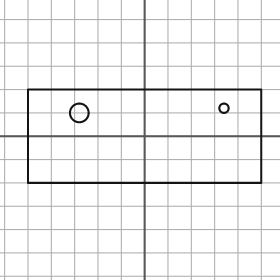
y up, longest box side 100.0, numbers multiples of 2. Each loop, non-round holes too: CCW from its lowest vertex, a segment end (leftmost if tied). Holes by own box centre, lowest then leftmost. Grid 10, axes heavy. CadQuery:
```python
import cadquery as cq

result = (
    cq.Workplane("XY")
    .moveTo(-50.0, -20.0)
    .lineTo(50.0, -20.0)
    .lineTo(50.0, 20.0)
    .lineTo(-50.0, 20.0)
    .close()
    .moveTo(-28.0, 10.0)
    .circle(4.0)
    .moveTo(34.0, 12.0)
    .circle(2.0)
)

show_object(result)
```